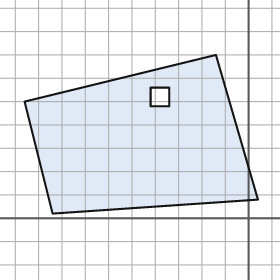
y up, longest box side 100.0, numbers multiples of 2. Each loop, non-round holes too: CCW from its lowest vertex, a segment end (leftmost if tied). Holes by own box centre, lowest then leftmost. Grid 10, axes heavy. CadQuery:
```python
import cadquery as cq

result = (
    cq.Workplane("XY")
    .moveTo(-84.0, 2.0)
    .lineTo(4.0, 8.0)
    .lineTo(-14.0, 70.0)
    .lineTo(-96.0, 50.0)
    .close()
    .moveTo(-42.0, 48.0)
    .lineTo(-34.0, 48.0)
    .lineTo(-34.0, 56.0)
    .lineTo(-42.0, 56.0)
    .close()
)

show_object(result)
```